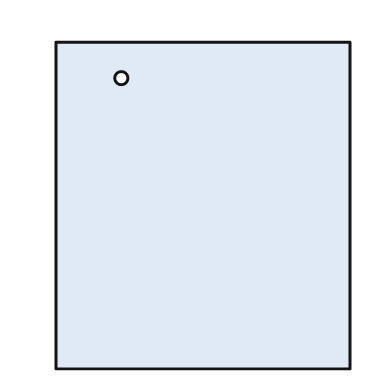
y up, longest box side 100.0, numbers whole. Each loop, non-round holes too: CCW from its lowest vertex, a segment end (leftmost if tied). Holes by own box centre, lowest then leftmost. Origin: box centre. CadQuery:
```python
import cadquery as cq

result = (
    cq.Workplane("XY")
    .moveTo(-45.0, -50.0)
    .lineTo(45.0, -50.0)
    .lineTo(45.0, 50.0)
    .lineTo(-45.0, 50.0)
    .close()
    .moveTo(-25.0, 39.0)
    .circle(2.0)
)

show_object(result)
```